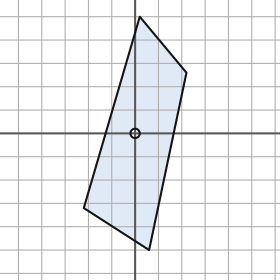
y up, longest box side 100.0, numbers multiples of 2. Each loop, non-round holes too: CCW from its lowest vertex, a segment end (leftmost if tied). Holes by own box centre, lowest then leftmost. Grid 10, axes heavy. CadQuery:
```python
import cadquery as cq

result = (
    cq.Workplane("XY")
    .moveTo(6.0, -50.0)
    .lineTo(22.0, 26.0)
    .lineTo(2.0, 50.0)
    .lineTo(-22.0, -32.0)
    .close()
    .moveTo(0.0, 0.0)
    .circle(2.0)
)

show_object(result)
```